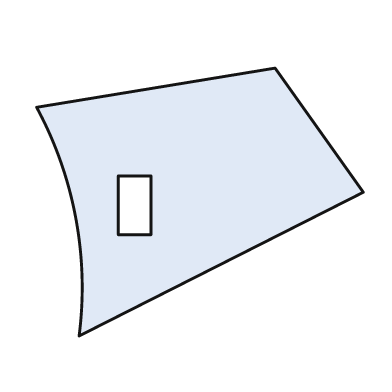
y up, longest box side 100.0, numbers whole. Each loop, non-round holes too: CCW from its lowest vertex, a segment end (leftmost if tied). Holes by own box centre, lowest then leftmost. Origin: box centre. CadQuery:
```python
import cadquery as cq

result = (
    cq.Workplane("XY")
    .moveTo(-37.0, -41.0)
    .lineTo(50.0, 3.0)
    .lineTo(23.0, 41.0)
    .lineTo(-50.0, 29.0)
    .threePointArc((-38.0, -5.0), (-37.0, -41.0))
    .close()
    .moveTo(-25.0, -10.0)
    .lineTo(-15.0, -10.0)
    .lineTo(-15.0, 8.0)
    .lineTo(-25.0, 8.0)
    .close()
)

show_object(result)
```